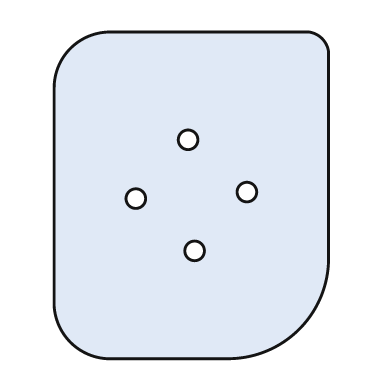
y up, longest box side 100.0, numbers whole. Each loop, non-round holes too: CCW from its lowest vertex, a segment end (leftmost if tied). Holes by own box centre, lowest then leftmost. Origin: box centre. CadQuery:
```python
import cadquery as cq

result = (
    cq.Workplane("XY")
    .moveTo(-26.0, -50.0)
    .lineTo(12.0, -50.0)
    .threePointArc((33.0, -41.0), (42.0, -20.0))
    .lineTo(42.0, 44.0)
    .threePointArc((40.0, 48.0), (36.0, 50.0))
    .lineTo(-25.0, 50.0)
    .threePointArc((-37.0, 45.0), (-42.0, 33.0))
    .lineTo(-42.0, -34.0)
    .threePointArc((-37.0, -45.0), (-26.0, -50.0))
    .close()
    .moveTo(1.0, -17.0)
    .circle(3.0)
    .moveTo(-17.0, -1.0)
    .circle(3.0)
    .moveTo(17.0, 1.0)
    .circle(3.0)
    .moveTo(-1.0, 17.0)
    .circle(3.0)
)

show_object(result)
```